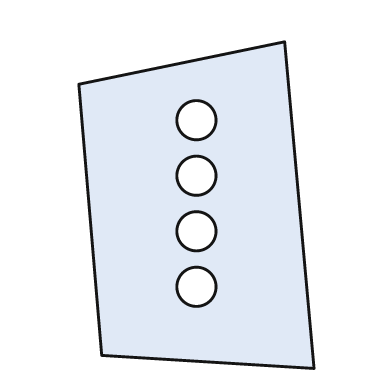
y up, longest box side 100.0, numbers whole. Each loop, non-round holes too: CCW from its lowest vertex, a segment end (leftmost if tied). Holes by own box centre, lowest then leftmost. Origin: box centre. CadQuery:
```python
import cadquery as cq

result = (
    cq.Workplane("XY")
    .moveTo(36.0, -50.0)
    .lineTo(27.0, 50.0)
    .lineTo(-36.0, 37.0)
    .lineTo(-29.0, -46.0)
    .close()
    .moveTo(0.0, -25.0)
    .circle(6.0)
    .moveTo(0.0, -8.0)
    .circle(6.0)
    .moveTo(0.0, 9.0)
    .circle(6.0)
    .moveTo(0.0, 26.0)
    .circle(6.0)
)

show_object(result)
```